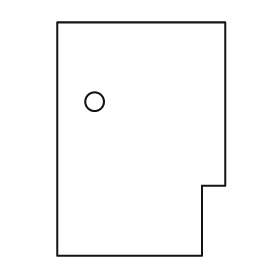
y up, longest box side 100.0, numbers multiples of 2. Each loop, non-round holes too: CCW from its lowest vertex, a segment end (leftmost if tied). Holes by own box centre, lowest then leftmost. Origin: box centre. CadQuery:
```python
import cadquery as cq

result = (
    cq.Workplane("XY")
    .moveTo(-36.0, -50.0)
    .lineTo(26.0, -50.0)
    .lineTo(26.0, -20.0)
    .lineTo(36.0, -20.0)
    .lineTo(36.0, 50.0)
    .lineTo(-36.0, 50.0)
    .close()
    .moveTo(-20.0, 16.0)
    .circle(4.0)
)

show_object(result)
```